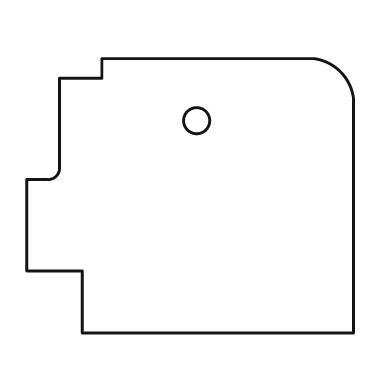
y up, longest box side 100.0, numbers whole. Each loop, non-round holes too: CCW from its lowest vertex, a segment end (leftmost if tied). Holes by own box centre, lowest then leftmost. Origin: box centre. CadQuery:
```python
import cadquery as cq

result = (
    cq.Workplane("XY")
    .moveTo(-33.0, -42.0)
    .lineTo(50.0, -42.0)
    .lineTo(50.0, 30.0)
    .threePointArc((46.0, 38.0), (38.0, 42.0))
    .lineTo(-27.0, 42.0)
    .lineTo(-27.0, 36.0)
    .lineTo(-40.0, 36.0)
    .lineTo(-40.0, 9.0)
    .threePointArc((-41.0, 6.0), (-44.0, 5.0))
    .lineTo(-50.0, 5.0)
    .lineTo(-50.0, -23.0)
    .lineTo(-33.0, -23.0)
    .close()
    .moveTo(2.0, 23.0)
    .circle(4.0)
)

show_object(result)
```